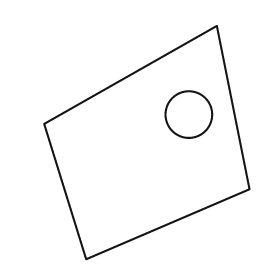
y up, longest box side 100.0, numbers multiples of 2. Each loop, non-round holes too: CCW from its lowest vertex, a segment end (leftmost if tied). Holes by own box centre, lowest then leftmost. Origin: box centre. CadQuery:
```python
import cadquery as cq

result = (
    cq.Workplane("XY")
    .moveTo(-26.0, -50.0)
    .lineTo(44.0, -20.0)
    .lineTo(30.0, 50.0)
    .lineTo(-44.0, 8.0)
    .close()
    .moveTo(18.0, 12.0)
    .circle(10.0)
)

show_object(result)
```